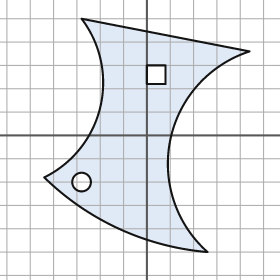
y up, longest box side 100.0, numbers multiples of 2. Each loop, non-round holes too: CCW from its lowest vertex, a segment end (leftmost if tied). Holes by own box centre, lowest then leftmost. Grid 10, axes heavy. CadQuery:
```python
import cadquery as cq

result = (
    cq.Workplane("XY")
    .moveTo(26.0, -50.0)
    .threePointArc((10.0, -2.0), (44.0, 36.0))
    .lineTo(-28.0, 50.0)
    .threePointArc((-20.0, 12.0), (-44.0, -18.0))
    .threePointArc((-12.0, -40.0), (26.0, -50.0))
    .close()
    .moveTo(-28.0, -20.0)
    .circle(4.0)
    .moveTo(0.0, 22.0)
    .lineTo(8.0, 22.0)
    .lineTo(8.0, 30.0)
    .lineTo(0.0, 30.0)
    .close()
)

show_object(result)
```